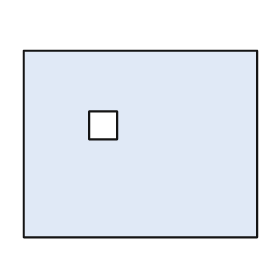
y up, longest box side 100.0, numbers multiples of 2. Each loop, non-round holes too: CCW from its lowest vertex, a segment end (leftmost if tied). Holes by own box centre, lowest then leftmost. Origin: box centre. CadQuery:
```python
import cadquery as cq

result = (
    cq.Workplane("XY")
    .moveTo(-50.0, -40.0)
    .lineTo(50.0, -40.0)
    .lineTo(50.0, 40.0)
    .lineTo(-50.0, 40.0)
    .close()
    .moveTo(-22.0, 2.0)
    .lineTo(-10.0, 2.0)
    .lineTo(-10.0, 14.0)
    .lineTo(-22.0, 14.0)
    .close()
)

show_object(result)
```